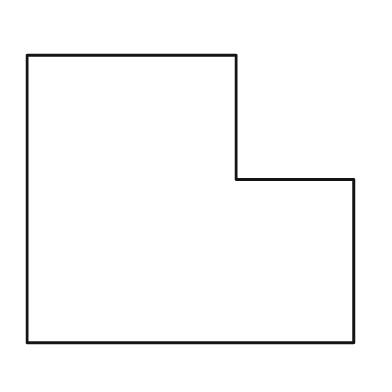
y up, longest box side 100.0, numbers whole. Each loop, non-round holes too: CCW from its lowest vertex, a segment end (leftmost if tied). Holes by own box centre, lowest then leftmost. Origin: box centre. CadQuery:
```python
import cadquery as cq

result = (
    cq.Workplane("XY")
    .moveTo(-50.0, -44.0)
    .lineTo(50.0, -44.0)
    .lineTo(50.0, 6.0)
    .lineTo(14.0, 6.0)
    .lineTo(14.0, 44.0)
    .lineTo(-50.0, 44.0)
    .close()
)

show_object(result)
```